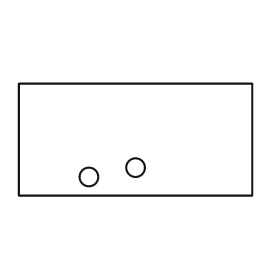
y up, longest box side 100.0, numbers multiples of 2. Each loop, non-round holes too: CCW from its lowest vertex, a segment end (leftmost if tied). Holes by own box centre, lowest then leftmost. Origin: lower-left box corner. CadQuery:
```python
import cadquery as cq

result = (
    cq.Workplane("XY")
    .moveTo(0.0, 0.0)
    .lineTo(100.0, 0.0)
    .lineTo(100.0, 48.0)
    .lineTo(0.0, 48.0)
    .close()
    .moveTo(30.0, 8.0)
    .circle(4.0)
    .moveTo(50.0, 12.0)
    .circle(4.0)
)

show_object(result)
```